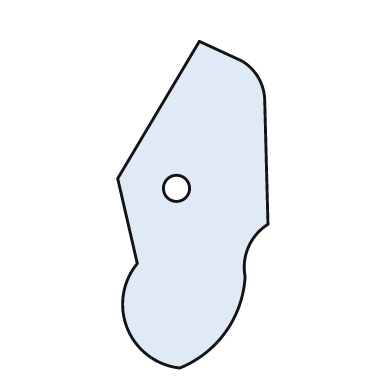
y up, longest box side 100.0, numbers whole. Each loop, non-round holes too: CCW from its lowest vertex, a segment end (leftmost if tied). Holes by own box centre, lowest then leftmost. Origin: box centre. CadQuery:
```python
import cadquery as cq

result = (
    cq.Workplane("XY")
    .moveTo(-4.0, -50.0)
    .threePointArc((10.0, -39.0), (16.0, -22.0))
    .threePointArc((17.0, -13.0), (23.0, -6.0))
    .lineTo(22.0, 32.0)
    .threePointArc((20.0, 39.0), (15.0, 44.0))
    .lineTo(2.0, 50.0)
    .lineTo(-23.0, 8.0)
    .lineTo(-17.0, -18.0)
    .threePointArc((-20.0, -38.0), (-4.0, -50.0))
    .close()
    .moveTo(-5.0, 5.0)
    .circle(4.0)
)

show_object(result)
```